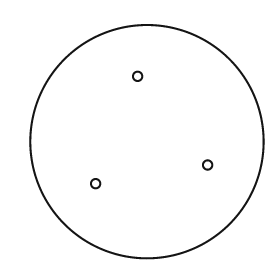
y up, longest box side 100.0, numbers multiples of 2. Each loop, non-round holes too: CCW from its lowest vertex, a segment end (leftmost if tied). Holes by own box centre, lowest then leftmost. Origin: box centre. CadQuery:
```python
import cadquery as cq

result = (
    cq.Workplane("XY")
    .moveTo(0.0, 0.0)
    .circle(50.0)
    .moveTo(-22.0, -18.0)
    .circle(2.0)
    .moveTo(26.0, -10.0)
    .circle(2.0)
    .moveTo(-4.0, 28.0)
    .circle(2.0)
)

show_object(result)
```